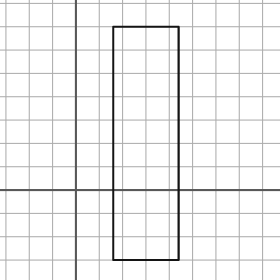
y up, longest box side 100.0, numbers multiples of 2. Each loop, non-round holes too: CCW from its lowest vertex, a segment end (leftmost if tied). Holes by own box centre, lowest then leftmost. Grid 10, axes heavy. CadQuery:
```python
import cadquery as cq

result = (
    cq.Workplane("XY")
    .moveTo(16.0, -30.0)
    .lineTo(44.0, -30.0)
    .lineTo(44.0, 70.0)
    .lineTo(16.0, 70.0)
    .close()
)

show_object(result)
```